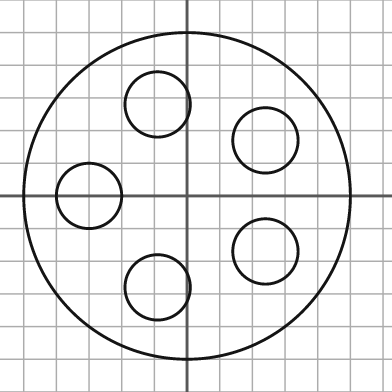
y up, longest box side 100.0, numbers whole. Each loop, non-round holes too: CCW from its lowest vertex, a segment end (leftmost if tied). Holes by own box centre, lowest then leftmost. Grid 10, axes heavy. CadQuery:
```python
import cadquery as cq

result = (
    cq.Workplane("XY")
    .moveTo(0.0, 0.0)
    .circle(50.0)
    .moveTo(-9.0, -28.0)
    .circle(10.0)
    .moveTo(24.0, -17.0)
    .circle(10.0)
    .moveTo(-30.0, 0.0)
    .circle(10.0)
    .moveTo(24.0, 17.0)
    .circle(10.0)
    .moveTo(-9.0, 28.0)
    .circle(10.0)
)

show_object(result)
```